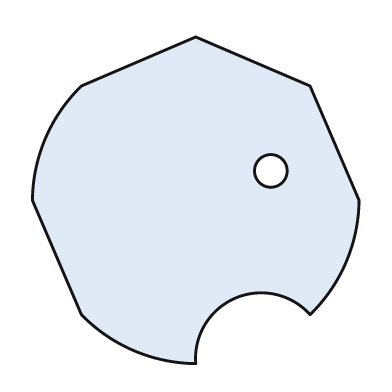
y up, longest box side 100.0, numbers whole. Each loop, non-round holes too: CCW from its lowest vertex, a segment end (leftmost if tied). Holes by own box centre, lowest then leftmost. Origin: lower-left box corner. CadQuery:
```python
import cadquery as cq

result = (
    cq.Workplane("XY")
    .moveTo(50.0, 0.0)
    .threePointArc((62.0, 20.0), (85.0, 15.0))
    .threePointArc((96.0, 31.0), (100.0, 50.0))
    .lineTo(85.0, 85.0)
    .lineTo(50.0, 100.0)
    .lineTo(15.0, 85.0)
    .threePointArc((4.0, 69.0), (0.0, 50.0))
    .lineTo(15.0, 15.0)
    .threePointArc((31.0, 4.0), (50.0, 0.0))
    .close()
    .moveTo(73.0, 59.0)
    .circle(5.0)
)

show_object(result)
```